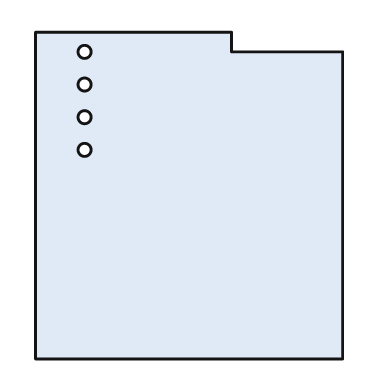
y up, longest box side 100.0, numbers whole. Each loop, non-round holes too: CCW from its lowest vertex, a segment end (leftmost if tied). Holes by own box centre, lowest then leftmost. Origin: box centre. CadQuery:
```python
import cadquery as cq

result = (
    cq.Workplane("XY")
    .moveTo(-47.0, -50.0)
    .lineTo(47.0, -50.0)
    .lineTo(47.0, 44.0)
    .lineTo(13.0, 44.0)
    .lineTo(13.0, 50.0)
    .lineTo(-47.0, 50.0)
    .close()
    .moveTo(-32.0, 14.0)
    .circle(2.0)
    .moveTo(-32.0, 24.0)
    .circle(2.0)
    .moveTo(-32.0, 34.0)
    .circle(2.0)
    .moveTo(-32.0, 44.0)
    .circle(2.0)
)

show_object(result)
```